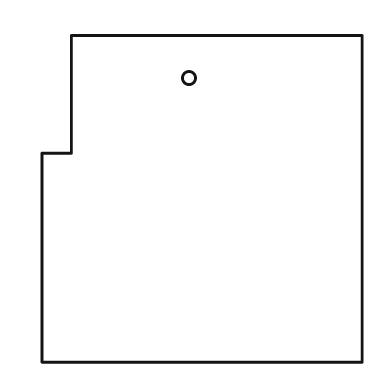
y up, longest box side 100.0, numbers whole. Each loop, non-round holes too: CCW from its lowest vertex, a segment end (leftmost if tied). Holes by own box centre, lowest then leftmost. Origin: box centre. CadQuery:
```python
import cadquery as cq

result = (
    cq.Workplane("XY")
    .moveTo(-49.0, -50.0)
    .lineTo(49.0, -50.0)
    .lineTo(49.0, 50.0)
    .lineTo(-40.0, 50.0)
    .lineTo(-40.0, 14.0)
    .lineTo(-49.0, 14.0)
    .close()
    .moveTo(-4.0, 37.0)
    .circle(2.0)
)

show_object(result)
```